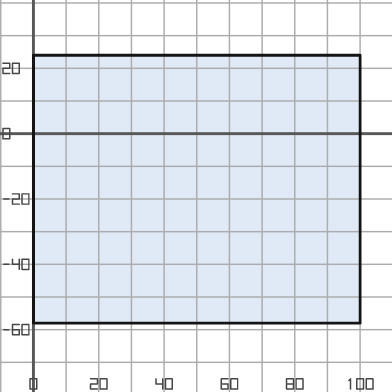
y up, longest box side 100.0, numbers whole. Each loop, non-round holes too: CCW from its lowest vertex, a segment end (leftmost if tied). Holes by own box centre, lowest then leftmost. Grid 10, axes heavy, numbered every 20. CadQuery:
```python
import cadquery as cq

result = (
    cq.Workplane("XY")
    .moveTo(0.0, -58.0)
    .lineTo(100.0, -58.0)
    .lineTo(100.0, 24.0)
    .lineTo(0.0, 24.0)
    .close()
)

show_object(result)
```